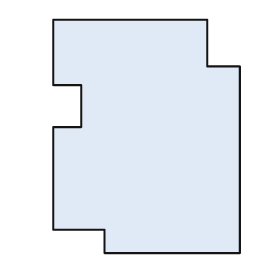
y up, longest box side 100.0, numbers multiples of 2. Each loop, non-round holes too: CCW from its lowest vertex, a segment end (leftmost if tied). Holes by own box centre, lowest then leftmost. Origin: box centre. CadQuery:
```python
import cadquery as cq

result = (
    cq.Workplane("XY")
    .moveTo(-18.0, -50.0)
    .lineTo(40.0, -50.0)
    .lineTo(40.0, 30.0)
    .lineTo(26.0, 30.0)
    .lineTo(26.0, 50.0)
    .lineTo(-40.0, 50.0)
    .lineTo(-40.0, 22.0)
    .lineTo(-28.0, 22.0)
    .lineTo(-28.0, 4.0)
    .lineTo(-40.0, 4.0)
    .lineTo(-40.0, -40.0)
    .lineTo(-18.0, -40.0)
    .close()
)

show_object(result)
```